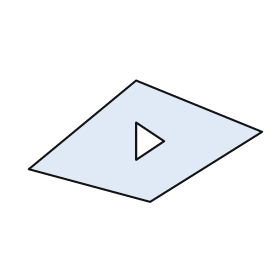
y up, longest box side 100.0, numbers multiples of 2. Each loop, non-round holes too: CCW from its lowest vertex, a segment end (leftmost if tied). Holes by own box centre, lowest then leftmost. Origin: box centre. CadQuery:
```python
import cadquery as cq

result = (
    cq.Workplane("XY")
    .moveTo(2.0, -26.0)
    .lineTo(50.0, 4.0)
    .lineTo(-4.0, 26.0)
    .lineTo(-50.0, -12.0)
    .close()
    .moveTo(-4.0, -8.0)
    .lineTo(8.0, 0.0)
    .lineTo(-4.0, 8.0)
    .close()
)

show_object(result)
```